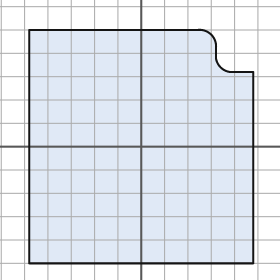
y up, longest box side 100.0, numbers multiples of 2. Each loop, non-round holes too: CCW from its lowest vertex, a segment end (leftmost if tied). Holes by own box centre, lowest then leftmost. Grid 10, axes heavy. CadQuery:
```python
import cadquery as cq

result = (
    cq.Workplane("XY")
    .moveTo(-48.0, -50.0)
    .lineTo(48.0, -50.0)
    .lineTo(48.0, 32.0)
    .lineTo(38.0, 32.0)
    .threePointArc((34.0, 34.0), (32.0, 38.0))
    .lineTo(32.0, 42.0)
    .threePointArc((30.0, 48.0), (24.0, 50.0))
    .lineTo(-48.0, 50.0)
    .close()
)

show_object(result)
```